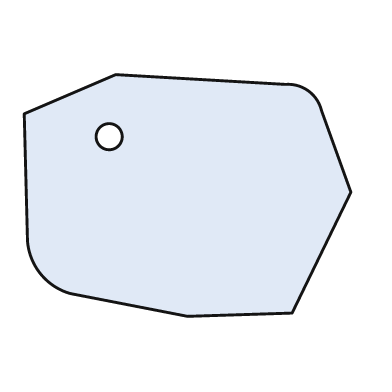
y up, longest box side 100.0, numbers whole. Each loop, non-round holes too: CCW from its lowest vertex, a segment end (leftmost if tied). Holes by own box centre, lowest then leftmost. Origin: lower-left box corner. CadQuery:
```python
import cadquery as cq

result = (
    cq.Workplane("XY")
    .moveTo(50.0, 0.0)
    .lineTo(82.0, 1.0)
    .lineTo(100.0, 38.0)
    .lineTo(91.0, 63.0)
    .threePointArc((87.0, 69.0), (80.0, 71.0))
    .lineTo(28.0, 74.0)
    .lineTo(0.0, 62.0)
    .lineTo(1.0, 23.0)
    .threePointArc((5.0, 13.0), (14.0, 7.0))
    .close()
    .moveTo(26.0, 55.0)
    .circle(4.0)
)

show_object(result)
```